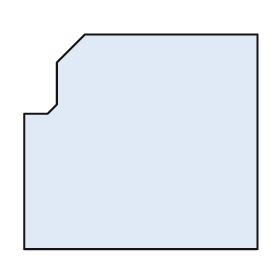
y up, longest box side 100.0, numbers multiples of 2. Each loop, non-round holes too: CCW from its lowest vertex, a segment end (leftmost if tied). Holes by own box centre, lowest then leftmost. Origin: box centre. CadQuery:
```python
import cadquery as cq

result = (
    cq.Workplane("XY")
    .moveTo(-50.0, -46.0)
    .lineTo(50.0, -46.0)
    .lineTo(50.0, 46.0)
    .lineTo(-24.0, 46.0)
    .lineTo(-36.0, 34.0)
    .lineTo(-36.0, 16.0)
    .lineTo(-40.0, 12.0)
    .lineTo(-50.0, 12.0)
    .close()
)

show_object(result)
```